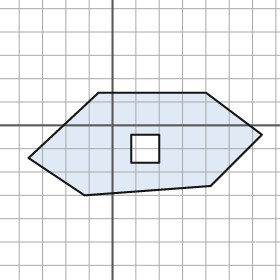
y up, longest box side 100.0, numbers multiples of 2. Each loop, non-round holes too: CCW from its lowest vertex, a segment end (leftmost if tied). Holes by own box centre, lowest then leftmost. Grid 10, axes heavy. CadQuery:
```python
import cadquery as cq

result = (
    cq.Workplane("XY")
    .moveTo(-12.0, -30.0)
    .lineTo(42.0, -26.0)
    .lineTo(64.0, -4.0)
    .lineTo(40.0, 14.0)
    .lineTo(-6.0, 14.0)
    .lineTo(-36.0, -14.0)
    .close()
    .moveTo(8.0, -16.0)
    .lineTo(20.0, -16.0)
    .lineTo(20.0, -4.0)
    .lineTo(8.0, -4.0)
    .close()
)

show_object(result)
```